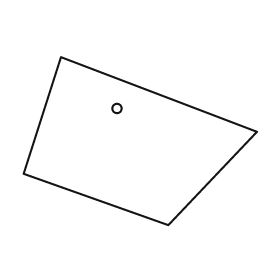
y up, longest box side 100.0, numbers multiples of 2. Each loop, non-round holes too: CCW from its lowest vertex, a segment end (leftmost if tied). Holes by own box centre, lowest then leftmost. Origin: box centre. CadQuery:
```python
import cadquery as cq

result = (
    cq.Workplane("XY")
    .moveTo(12.0, -36.0)
    .lineTo(50.0, 4.0)
    .lineTo(-34.0, 36.0)
    .lineTo(-50.0, -14.0)
    .close()
    .moveTo(-10.0, 14.0)
    .circle(2.0)
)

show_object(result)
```